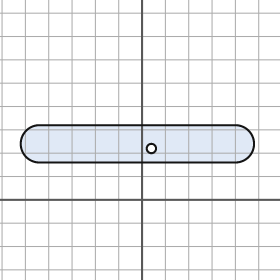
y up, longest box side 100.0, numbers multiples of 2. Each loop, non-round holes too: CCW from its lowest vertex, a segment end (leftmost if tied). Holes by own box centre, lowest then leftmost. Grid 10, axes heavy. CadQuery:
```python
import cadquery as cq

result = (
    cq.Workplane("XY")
    .moveTo(-44.0, 16.0)
    .lineTo(40.0, 16.0)
    .threePointArc((48.0, 24.0), (40.0, 32.0))
    .lineTo(-44.0, 32.0)
    .threePointArc((-52.0, 24.0), (-44.0, 16.0))
    .close()
    .moveTo(4.0, 22.0)
    .circle(2.0)
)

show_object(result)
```